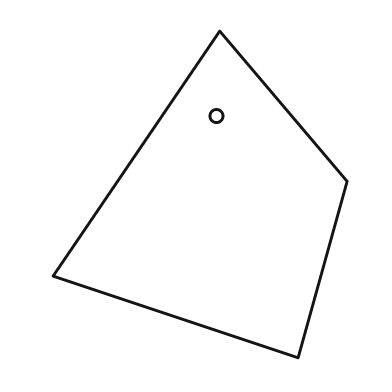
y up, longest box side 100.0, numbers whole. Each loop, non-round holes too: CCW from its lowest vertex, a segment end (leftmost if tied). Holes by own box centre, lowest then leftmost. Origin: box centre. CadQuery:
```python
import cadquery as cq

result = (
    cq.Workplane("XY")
    .moveTo(30.0, -50.0)
    .lineTo(45.0, 4.0)
    .lineTo(6.0, 50.0)
    .lineTo(-45.0, -25.0)
    .close()
    .moveTo(5.0, 24.0)
    .circle(2.0)
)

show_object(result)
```